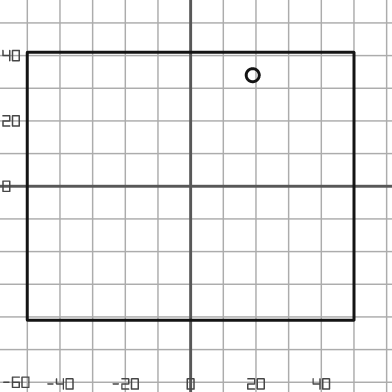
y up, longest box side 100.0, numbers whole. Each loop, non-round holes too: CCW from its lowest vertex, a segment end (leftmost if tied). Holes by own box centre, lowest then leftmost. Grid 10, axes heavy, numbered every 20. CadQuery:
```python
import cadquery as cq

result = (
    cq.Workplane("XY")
    .moveTo(-50.0, -41.0)
    .lineTo(50.0, -41.0)
    .lineTo(50.0, 41.0)
    .lineTo(-50.0, 41.0)
    .close()
    .moveTo(19.0, 34.0)
    .circle(2.0)
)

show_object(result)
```